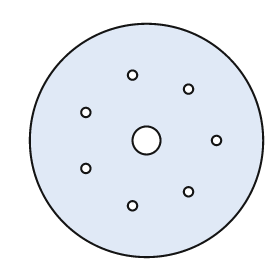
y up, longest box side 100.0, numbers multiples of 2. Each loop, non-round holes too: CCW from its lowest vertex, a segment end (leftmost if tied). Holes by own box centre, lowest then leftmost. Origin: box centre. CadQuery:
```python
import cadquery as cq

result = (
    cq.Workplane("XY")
    .moveTo(0.0, 0.0)
    .circle(50.0)
    .moveTo(-6.0, -28.0)
    .circle(2.0)
    .moveTo(18.0, -22.0)
    .circle(2.0)
    .moveTo(-26.0, -12.0)
    .circle(2.0)
    .moveTo(0.0, 0.0)
    .circle(6.0)
    .moveTo(30.0, 0.0)
    .circle(2.0)
    .moveTo(-26.0, 12.0)
    .circle(2.0)
    .moveTo(18.0, 22.0)
    .circle(2.0)
    .moveTo(-6.0, 28.0)
    .circle(2.0)
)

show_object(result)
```